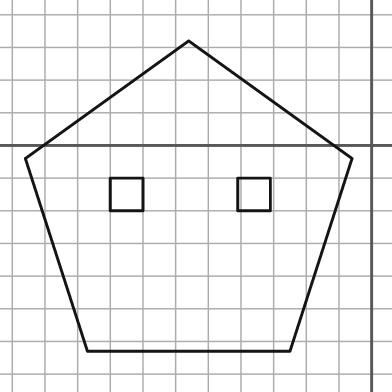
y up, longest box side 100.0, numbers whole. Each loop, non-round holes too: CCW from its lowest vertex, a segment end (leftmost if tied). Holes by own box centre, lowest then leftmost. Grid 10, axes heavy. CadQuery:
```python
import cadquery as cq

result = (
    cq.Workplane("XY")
    .moveTo(-87.0, -63.0)
    .lineTo(-25.0, -63.0)
    .lineTo(-6.0, -4.0)
    .lineTo(-56.0, 32.0)
    .lineTo(-106.0, -4.0)
    .close()
    .moveTo(-80.0, -20.0)
    .lineTo(-70.0, -20.0)
    .lineTo(-70.0, -10.0)
    .lineTo(-80.0, -10.0)
    .close()
    .moveTo(-41.0, -20.0)
    .lineTo(-31.0, -20.0)
    .lineTo(-31.0, -10.0)
    .lineTo(-41.0, -10.0)
    .close()
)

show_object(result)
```